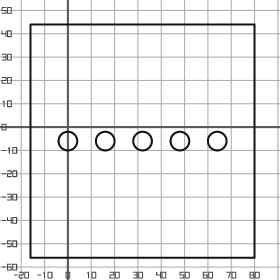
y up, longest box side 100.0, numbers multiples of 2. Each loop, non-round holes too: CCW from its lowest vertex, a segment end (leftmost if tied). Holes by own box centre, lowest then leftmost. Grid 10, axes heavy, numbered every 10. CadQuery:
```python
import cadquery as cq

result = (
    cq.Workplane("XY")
    .moveTo(-16.0, -56.0)
    .lineTo(80.0, -56.0)
    .lineTo(80.0, 44.0)
    .lineTo(-16.0, 44.0)
    .close()
    .moveTo(0.0, -6.0)
    .circle(4.0)
    .moveTo(16.0, -6.0)
    .circle(4.0)
    .moveTo(32.0, -6.0)
    .circle(4.0)
    .moveTo(48.0, -6.0)
    .circle(4.0)
    .moveTo(64.0, -6.0)
    .circle(4.0)
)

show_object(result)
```